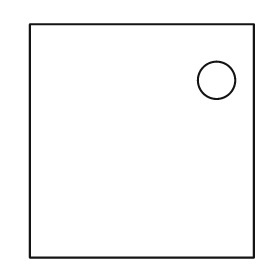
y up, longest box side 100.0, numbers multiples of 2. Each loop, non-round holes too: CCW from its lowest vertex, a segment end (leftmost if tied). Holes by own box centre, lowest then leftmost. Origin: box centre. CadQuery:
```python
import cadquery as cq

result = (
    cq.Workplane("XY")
    .moveTo(-48.0, -50.0)
    .lineTo(48.0, -50.0)
    .lineTo(48.0, 50.0)
    .lineTo(-48.0, 50.0)
    .close()
    .moveTo(32.0, 26.0)
    .circle(8.0)
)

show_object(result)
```